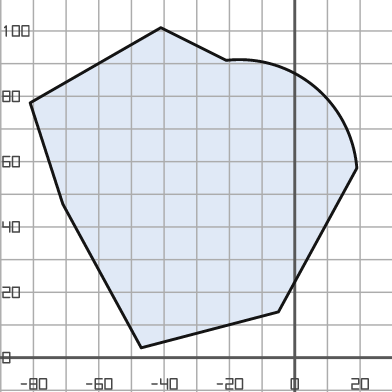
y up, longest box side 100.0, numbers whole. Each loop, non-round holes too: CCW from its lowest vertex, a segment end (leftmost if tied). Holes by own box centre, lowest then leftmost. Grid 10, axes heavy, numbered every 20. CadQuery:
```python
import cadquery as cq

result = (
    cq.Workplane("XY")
    .moveTo(-47.0, 3.0)
    .lineTo(-5.0, 14.0)
    .lineTo(19.0, 58.0)
    .threePointArc((6.0, 83.0), (-21.0, 91.0))
    .lineTo(-41.0, 101.0)
    .lineTo(-81.0, 78.0)
    .lineTo(-71.0, 47.0)
    .close()
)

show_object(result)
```